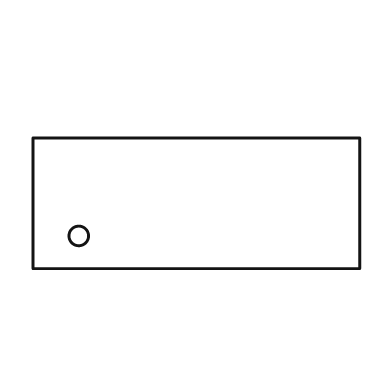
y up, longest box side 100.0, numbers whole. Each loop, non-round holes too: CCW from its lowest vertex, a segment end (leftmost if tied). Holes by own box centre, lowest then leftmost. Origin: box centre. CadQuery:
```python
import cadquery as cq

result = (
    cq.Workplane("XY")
    .moveTo(-50.0, -20.0)
    .lineTo(50.0, -20.0)
    .lineTo(50.0, 20.0)
    .lineTo(-50.0, 20.0)
    .close()
    .moveTo(-36.0, -10.0)
    .circle(3.0)
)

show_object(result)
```